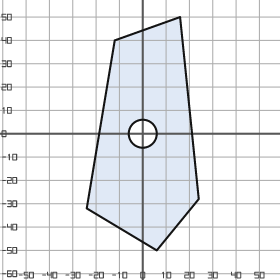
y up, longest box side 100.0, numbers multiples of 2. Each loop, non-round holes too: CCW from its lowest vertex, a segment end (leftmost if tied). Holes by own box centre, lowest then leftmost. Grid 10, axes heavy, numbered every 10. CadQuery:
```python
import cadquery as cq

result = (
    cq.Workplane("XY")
    .moveTo(6.0, -50.0)
    .lineTo(24.0, -28.0)
    .lineTo(16.0, 50.0)
    .lineTo(-12.0, 40.0)
    .lineTo(-24.0, -32.0)
    .close()
    .moveTo(0.0, 0.0)
    .circle(6.0)
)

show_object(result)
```